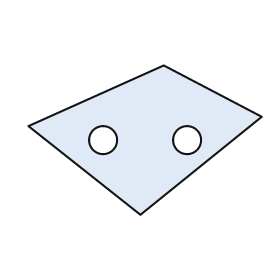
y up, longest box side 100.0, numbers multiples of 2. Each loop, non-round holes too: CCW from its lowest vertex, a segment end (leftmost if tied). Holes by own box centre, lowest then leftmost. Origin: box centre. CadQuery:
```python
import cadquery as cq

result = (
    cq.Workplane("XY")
    .moveTo(-2.0, -32.0)
    .lineTo(50.0, 10.0)
    .lineTo(8.0, 32.0)
    .lineTo(-50.0, 6.0)
    .close()
    .moveTo(-18.0, 0.0)
    .circle(6.0)
    .moveTo(18.0, 0.0)
    .circle(6.0)
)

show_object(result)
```